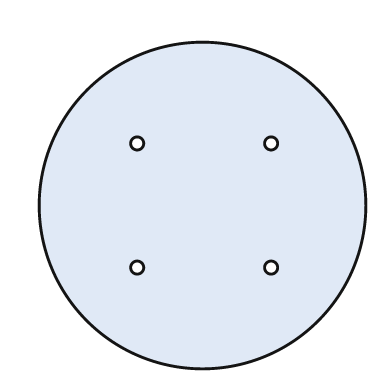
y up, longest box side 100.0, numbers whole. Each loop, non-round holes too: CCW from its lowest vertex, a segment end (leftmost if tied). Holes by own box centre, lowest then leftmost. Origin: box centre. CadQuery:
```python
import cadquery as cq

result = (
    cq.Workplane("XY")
    .moveTo(0.0, 0.0)
    .circle(50.0)
    .moveTo(-20.0, -19.0)
    .circle(2.0)
    .moveTo(21.0, -19.0)
    .circle(2.0)
    .moveTo(-20.0, 19.0)
    .circle(2.0)
    .moveTo(21.0, 19.0)
    .circle(2.0)
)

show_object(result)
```